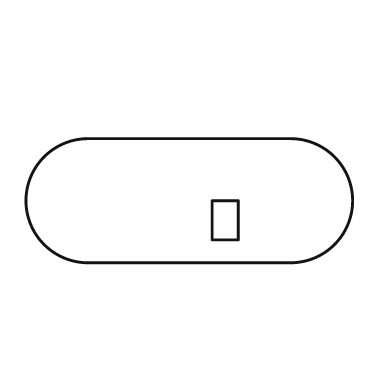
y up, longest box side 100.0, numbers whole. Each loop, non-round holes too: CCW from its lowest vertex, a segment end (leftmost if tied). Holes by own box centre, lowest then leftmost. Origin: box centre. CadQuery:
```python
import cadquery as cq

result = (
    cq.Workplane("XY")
    .moveTo(-31.0, -19.0)
    .lineTo(31.0, -19.0)
    .threePointArc((50.0, 0.0), (31.0, 19.0))
    .lineTo(-31.0, 19.0)
    .threePointArc((-50.0, 0.0), (-31.0, -19.0))
    .close()
    .moveTo(7.0, -12.0)
    .lineTo(15.0, -12.0)
    .lineTo(15.0, 0.0)
    .lineTo(7.0, 0.0)
    .close()
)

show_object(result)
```